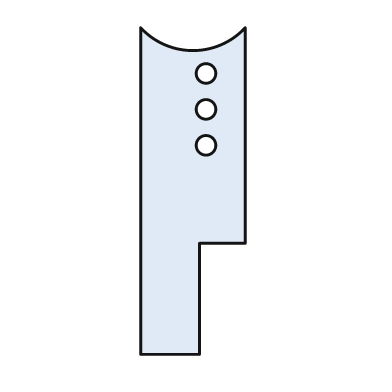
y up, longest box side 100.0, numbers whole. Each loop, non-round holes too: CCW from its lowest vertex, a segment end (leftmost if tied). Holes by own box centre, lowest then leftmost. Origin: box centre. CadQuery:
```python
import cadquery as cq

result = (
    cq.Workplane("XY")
    .moveTo(-16.0, -50.0)
    .lineTo(2.0, -50.0)
    .lineTo(2.0, -16.0)
    .lineTo(16.0, -16.0)
    .lineTo(16.0, 50.0)
    .threePointArc((0.0, 43.0), (-16.0, 50.0))
    .close()
    .moveTo(4.0, 14.0)
    .circle(3.0)
    .moveTo(4.0, 25.0)
    .circle(3.0)
    .moveTo(4.0, 36.0)
    .circle(3.0)
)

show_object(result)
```